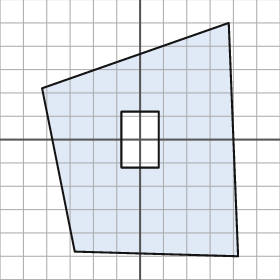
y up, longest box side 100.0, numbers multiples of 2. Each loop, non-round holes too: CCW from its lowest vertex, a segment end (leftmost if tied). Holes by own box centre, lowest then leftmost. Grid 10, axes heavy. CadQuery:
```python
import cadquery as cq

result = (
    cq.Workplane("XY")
    .moveTo(42.0, -50.0)
    .lineTo(38.0, 50.0)
    .lineTo(-42.0, 22.0)
    .lineTo(-28.0, -48.0)
    .close()
    .moveTo(-8.0, -12.0)
    .lineTo(8.0, -12.0)
    .lineTo(8.0, 12.0)
    .lineTo(-8.0, 12.0)
    .close()
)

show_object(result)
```